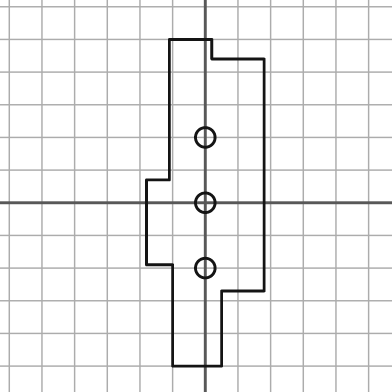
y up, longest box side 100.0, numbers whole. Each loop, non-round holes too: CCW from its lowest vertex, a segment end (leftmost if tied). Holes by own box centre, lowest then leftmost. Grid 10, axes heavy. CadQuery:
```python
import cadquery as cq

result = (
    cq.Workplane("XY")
    .moveTo(-10.0, -50.0)
    .lineTo(5.0, -50.0)
    .lineTo(5.0, -27.0)
    .lineTo(18.0, -27.0)
    .lineTo(18.0, 44.0)
    .lineTo(2.0, 44.0)
    .lineTo(2.0, 50.0)
    .lineTo(-11.0, 50.0)
    .lineTo(-11.0, 7.0)
    .lineTo(-18.0, 7.0)
    .lineTo(-18.0, -19.0)
    .lineTo(-10.0, -19.0)
    .close()
    .moveTo(0.0, -20.0)
    .circle(3.0)
    .moveTo(0.0, 0.0)
    .circle(3.0)
    .moveTo(0.0, 20.0)
    .circle(3.0)
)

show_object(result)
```